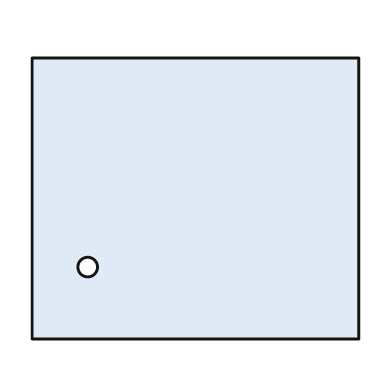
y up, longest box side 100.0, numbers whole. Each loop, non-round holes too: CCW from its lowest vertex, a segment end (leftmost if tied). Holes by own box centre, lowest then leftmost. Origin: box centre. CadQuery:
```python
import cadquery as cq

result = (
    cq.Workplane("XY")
    .moveTo(-50.0, -43.0)
    .lineTo(50.0, -43.0)
    .lineTo(50.0, 43.0)
    .lineTo(-50.0, 43.0)
    .close()
    .moveTo(-33.0, -21.0)
    .circle(3.0)
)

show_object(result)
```